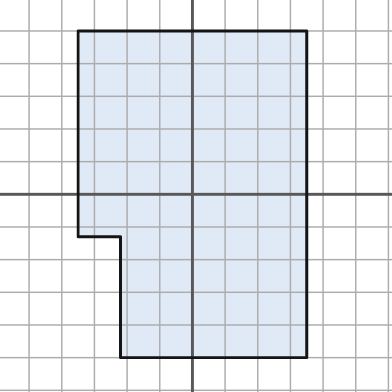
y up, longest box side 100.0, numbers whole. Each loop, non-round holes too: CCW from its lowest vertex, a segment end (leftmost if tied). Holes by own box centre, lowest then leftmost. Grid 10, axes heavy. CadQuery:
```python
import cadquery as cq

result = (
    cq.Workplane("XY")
    .moveTo(-22.0, -50.0)
    .lineTo(35.0, -50.0)
    .lineTo(35.0, 50.0)
    .lineTo(-35.0, 50.0)
    .lineTo(-35.0, -13.0)
    .lineTo(-22.0, -13.0)
    .close()
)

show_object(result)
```